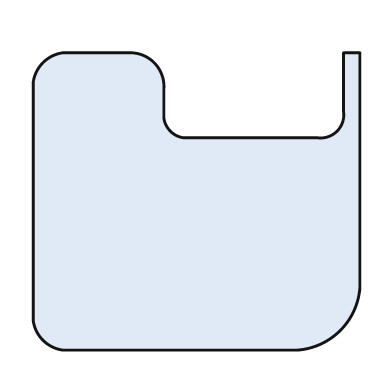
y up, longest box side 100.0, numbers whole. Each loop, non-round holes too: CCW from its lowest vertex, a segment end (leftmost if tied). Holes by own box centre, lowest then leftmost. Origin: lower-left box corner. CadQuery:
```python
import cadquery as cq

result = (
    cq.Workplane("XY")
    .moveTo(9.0, 0.0)
    .lineTo(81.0, 0.0)
    .threePointArc((94.0, 6.0), (100.0, 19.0))
    .lineTo(100.0, 91.0)
    .lineTo(95.0, 91.0)
    .lineTo(95.0, 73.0)
    .threePointArc((93.0, 67.0), (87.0, 65.0))
    .lineTo(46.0, 65.0)
    .threePointArc((42.0, 67.0), (40.0, 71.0))
    .lineTo(40.0, 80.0)
    .threePointArc((37.0, 88.0), (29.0, 91.0))
    .lineTo(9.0, 91.0)
    .threePointArc((3.0, 88.0), (0.0, 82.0))
    .lineTo(0.0, 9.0)
    .threePointArc((3.0, 3.0), (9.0, 0.0))
    .close()
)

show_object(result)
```